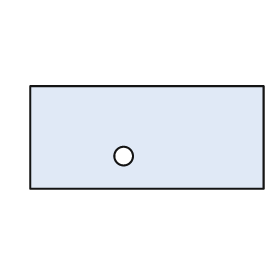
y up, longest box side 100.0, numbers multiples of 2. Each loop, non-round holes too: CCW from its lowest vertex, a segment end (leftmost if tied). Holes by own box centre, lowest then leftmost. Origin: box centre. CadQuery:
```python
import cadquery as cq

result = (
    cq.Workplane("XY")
    .moveTo(-50.0, -22.0)
    .lineTo(50.0, -22.0)
    .lineTo(50.0, 22.0)
    .lineTo(-50.0, 22.0)
    .close()
    .moveTo(-10.0, -8.0)
    .circle(4.0)
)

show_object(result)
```